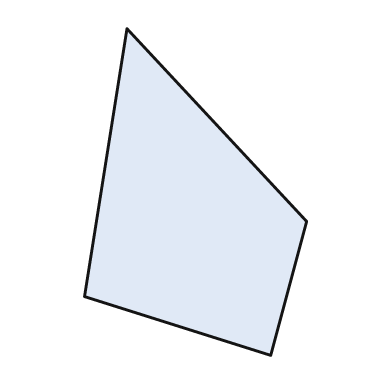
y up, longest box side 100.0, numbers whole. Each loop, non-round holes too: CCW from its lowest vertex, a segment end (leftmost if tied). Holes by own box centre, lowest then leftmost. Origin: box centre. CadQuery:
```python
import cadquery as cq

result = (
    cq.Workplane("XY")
    .moveTo(23.0, -50.0)
    .lineTo(34.0, -9.0)
    .lineTo(-21.0, 50.0)
    .lineTo(-34.0, -32.0)
    .close()
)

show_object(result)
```